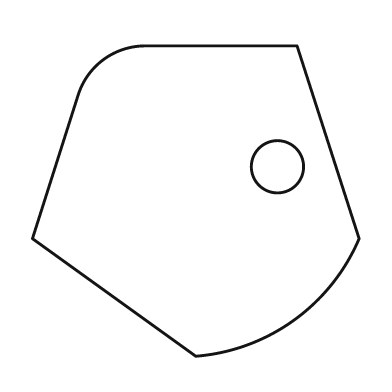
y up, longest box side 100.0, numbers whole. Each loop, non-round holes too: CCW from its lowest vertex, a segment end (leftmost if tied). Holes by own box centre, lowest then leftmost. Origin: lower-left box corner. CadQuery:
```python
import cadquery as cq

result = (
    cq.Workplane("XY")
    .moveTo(50.0, 0.0)
    .threePointArc((80.0, 11.0), (100.0, 36.0))
    .lineTo(81.0, 95.0)
    .lineTo(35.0, 95.0)
    .threePointArc((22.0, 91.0), (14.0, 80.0))
    .lineTo(0.0, 36.0)
    .close()
    .moveTo(75.0, 58.0)
    .circle(8.0)
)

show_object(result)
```